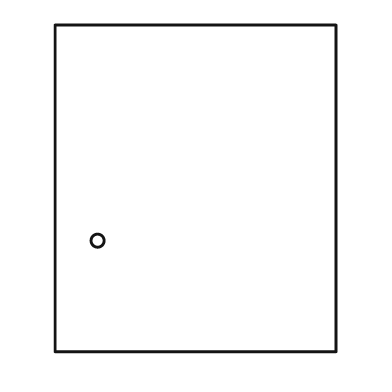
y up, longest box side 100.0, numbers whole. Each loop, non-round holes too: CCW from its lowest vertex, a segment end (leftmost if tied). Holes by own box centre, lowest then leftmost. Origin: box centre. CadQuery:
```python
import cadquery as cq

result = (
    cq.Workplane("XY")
    .moveTo(-43.0, -50.0)
    .lineTo(43.0, -50.0)
    .lineTo(43.0, 50.0)
    .lineTo(-43.0, 50.0)
    .close()
    .moveTo(-30.0, -16.0)
    .circle(2.0)
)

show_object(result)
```